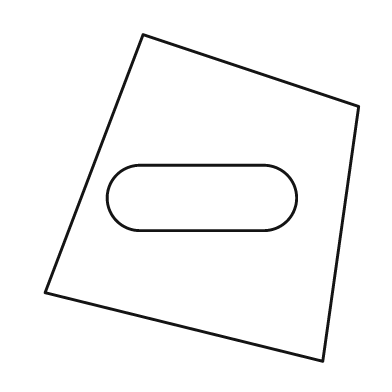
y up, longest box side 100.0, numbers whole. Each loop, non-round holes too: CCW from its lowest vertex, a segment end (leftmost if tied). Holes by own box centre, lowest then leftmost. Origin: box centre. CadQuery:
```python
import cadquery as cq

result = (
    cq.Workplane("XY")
    .moveTo(37.0, -50.0)
    .lineTo(48.0, 28.0)
    .lineTo(-18.0, 50.0)
    .lineTo(-48.0, -29.0)
    .close()
    .moveTo(-19.0, -10.0)
    .lineTo(19.0, -10.0)
    .threePointArc((29.0, 0.0), (19.0, 10.0))
    .lineTo(-19.0, 10.0)
    .threePointArc((-29.0, 0.0), (-19.0, -10.0))
    .close()
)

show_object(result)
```